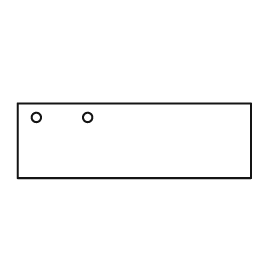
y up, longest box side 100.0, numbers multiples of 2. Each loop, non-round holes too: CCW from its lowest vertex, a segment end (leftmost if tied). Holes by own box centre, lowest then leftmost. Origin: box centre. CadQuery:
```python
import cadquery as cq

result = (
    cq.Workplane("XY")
    .moveTo(-50.0, -16.0)
    .lineTo(50.0, -16.0)
    .lineTo(50.0, 16.0)
    .lineTo(-50.0, 16.0)
    .close()
    .moveTo(-42.0, 10.0)
    .circle(2.0)
    .moveTo(-20.0, 10.0)
    .circle(2.0)
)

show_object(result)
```